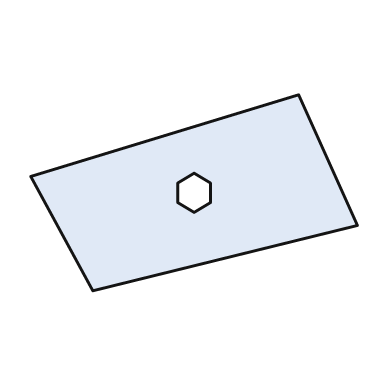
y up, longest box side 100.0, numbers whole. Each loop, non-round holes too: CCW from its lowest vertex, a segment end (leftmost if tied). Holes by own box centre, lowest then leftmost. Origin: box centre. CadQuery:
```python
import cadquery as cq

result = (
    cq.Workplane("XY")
    .moveTo(-31.0, -30.0)
    .lineTo(50.0, -10.0)
    .lineTo(32.0, 30.0)
    .lineTo(-50.0, 5.0)
    .close()
    .moveTo(0.0, -6.0)
    .lineTo(5.0, -3.0)
    .lineTo(5.0, 3.0)
    .lineTo(0.0, 6.0)
    .lineTo(-5.0, 3.0)
    .lineTo(-5.0, -3.0)
    .close()
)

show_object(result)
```